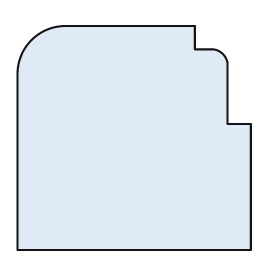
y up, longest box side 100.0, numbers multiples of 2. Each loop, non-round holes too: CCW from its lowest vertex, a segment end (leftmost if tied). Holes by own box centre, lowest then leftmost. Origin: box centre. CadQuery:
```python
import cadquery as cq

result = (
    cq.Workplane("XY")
    .moveTo(-50.0, -48.0)
    .lineTo(50.0, -48.0)
    .lineTo(50.0, 6.0)
    .lineTo(40.0, 6.0)
    .lineTo(40.0, 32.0)
    .threePointArc((38.0, 36.0), (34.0, 38.0))
    .lineTo(26.0, 38.0)
    .lineTo(26.0, 48.0)
    .lineTo(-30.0, 48.0)
    .threePointArc((-44.0, 42.0), (-50.0, 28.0))
    .close()
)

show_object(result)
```